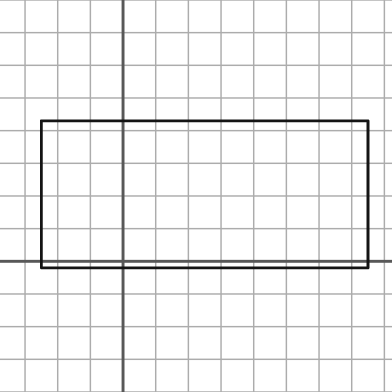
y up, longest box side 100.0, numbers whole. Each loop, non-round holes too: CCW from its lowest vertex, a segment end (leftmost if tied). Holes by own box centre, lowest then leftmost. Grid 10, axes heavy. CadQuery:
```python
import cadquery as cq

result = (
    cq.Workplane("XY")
    .moveTo(-25.0, -2.0)
    .lineTo(75.0, -2.0)
    .lineTo(75.0, 43.0)
    .lineTo(-25.0, 43.0)
    .close()
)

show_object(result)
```